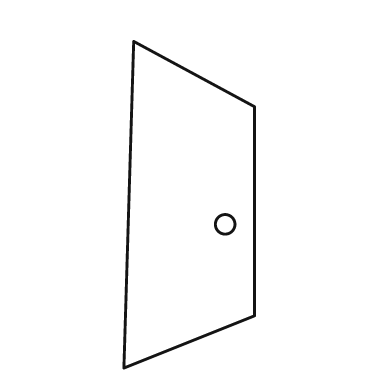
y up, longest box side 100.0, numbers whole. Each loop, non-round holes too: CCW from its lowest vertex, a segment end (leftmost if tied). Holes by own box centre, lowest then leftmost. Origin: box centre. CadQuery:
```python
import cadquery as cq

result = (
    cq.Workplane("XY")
    .moveTo(-20.0, -50.0)
    .lineTo(20.0, -34.0)
    .lineTo(20.0, 30.0)
    .lineTo(-17.0, 50.0)
    .close()
    .moveTo(11.0, -6.0)
    .circle(3.0)
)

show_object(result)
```